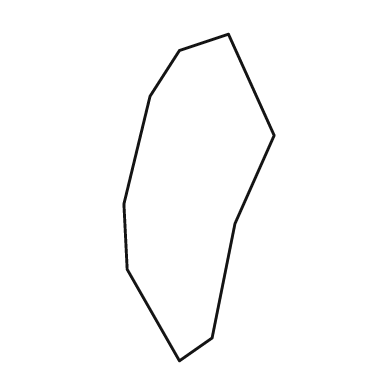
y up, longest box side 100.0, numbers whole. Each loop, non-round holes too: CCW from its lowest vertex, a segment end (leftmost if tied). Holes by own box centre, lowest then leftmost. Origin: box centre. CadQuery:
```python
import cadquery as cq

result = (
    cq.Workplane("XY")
    .moveTo(-6.0, -50.0)
    .lineTo(4.0, -43.0)
    .lineTo(11.0, -8.0)
    .lineTo(23.0, 19.0)
    .lineTo(9.0, 50.0)
    .lineTo(-6.0, 45.0)
    .lineTo(-15.0, 31.0)
    .lineTo(-23.0, -2.0)
    .lineTo(-22.0, -22.0)
    .close()
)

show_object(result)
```